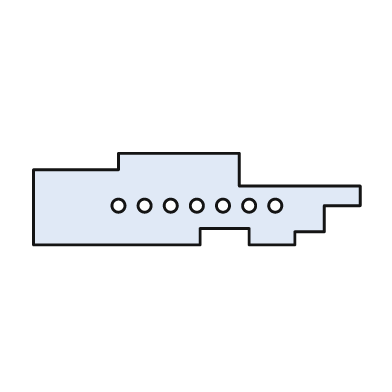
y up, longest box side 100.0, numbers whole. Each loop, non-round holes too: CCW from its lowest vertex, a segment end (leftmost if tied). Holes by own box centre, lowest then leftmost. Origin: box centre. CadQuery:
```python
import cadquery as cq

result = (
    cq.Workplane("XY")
    .moveTo(-50.0, -14.0)
    .lineTo(1.0, -14.0)
    .lineTo(1.0, -9.0)
    .lineTo(16.0, -9.0)
    .lineTo(16.0, -14.0)
    .lineTo(30.0, -14.0)
    .lineTo(30.0, -10.0)
    .lineTo(39.0, -10.0)
    .lineTo(39.0, -2.0)
    .lineTo(50.0, -2.0)
    .lineTo(50.0, 4.0)
    .lineTo(13.0, 4.0)
    .lineTo(13.0, 14.0)
    .lineTo(-24.0, 14.0)
    .lineTo(-24.0, 9.0)
    .lineTo(-50.0, 9.0)
    .close()
    .moveTo(-24.0, -2.0)
    .circle(2.0)
    .moveTo(-16.0, -2.0)
    .circle(2.0)
    .moveTo(-8.0, -2.0)
    .circle(2.0)
    .moveTo(0.0, -2.0)
    .circle(2.0)
    .moveTo(8.0, -2.0)
    .circle(2.0)
    .moveTo(16.0, -2.0)
    .circle(2.0)
    .moveTo(24.0, -2.0)
    .circle(2.0)
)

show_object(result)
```